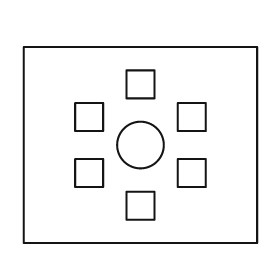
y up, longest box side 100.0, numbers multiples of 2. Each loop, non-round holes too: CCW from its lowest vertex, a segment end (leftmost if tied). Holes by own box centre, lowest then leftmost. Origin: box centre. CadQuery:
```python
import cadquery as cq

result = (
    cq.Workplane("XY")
    .moveTo(-50.0, -42.0)
    .lineTo(50.0, -42.0)
    .lineTo(50.0, 42.0)
    .lineTo(-50.0, 42.0)
    .close()
    .moveTo(-6.0, -32.0)
    .lineTo(6.0, -32.0)
    .lineTo(6.0, -20.0)
    .lineTo(-6.0, -20.0)
    .close()
    .moveTo(-28.0, -18.0)
    .lineTo(-16.0, -18.0)
    .lineTo(-16.0, -6.0)
    .lineTo(-28.0, -6.0)
    .close()
    .moveTo(16.0, -18.0)
    .lineTo(28.0, -18.0)
    .lineTo(28.0, -6.0)
    .lineTo(16.0, -6.0)
    .close()
    .moveTo(0.0, 0.0)
    .circle(10.0)
    .moveTo(-28.0, 6.0)
    .lineTo(-16.0, 6.0)
    .lineTo(-16.0, 18.0)
    .lineTo(-28.0, 18.0)
    .close()
    .moveTo(16.0, 6.0)
    .lineTo(28.0, 6.0)
    .lineTo(28.0, 18.0)
    .lineTo(16.0, 18.0)
    .close()
    .moveTo(-6.0, 20.0)
    .lineTo(6.0, 20.0)
    .lineTo(6.0, 32.0)
    .lineTo(-6.0, 32.0)
    .close()
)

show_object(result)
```